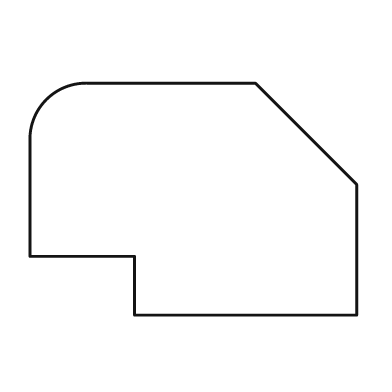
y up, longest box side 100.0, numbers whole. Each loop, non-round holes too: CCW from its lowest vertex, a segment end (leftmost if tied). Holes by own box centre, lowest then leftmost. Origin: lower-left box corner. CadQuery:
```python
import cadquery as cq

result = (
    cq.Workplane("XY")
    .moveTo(32.0, 0.0)
    .lineTo(100.0, 0.0)
    .lineTo(100.0, 40.0)
    .lineTo(69.0, 71.0)
    .lineTo(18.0, 71.0)
    .threePointArc((5.0, 66.0), (0.0, 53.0))
    .lineTo(0.0, 18.0)
    .lineTo(32.0, 18.0)
    .close()
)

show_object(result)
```